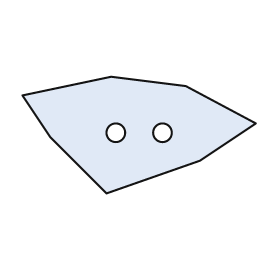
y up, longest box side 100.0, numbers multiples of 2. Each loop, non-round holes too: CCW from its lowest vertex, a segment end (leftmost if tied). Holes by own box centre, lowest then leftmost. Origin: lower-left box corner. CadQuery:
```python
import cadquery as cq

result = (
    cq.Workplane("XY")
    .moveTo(36.0, 0.0)
    .lineTo(76.0, 14.0)
    .lineTo(100.0, 30.0)
    .lineTo(70.0, 46.0)
    .lineTo(38.0, 50.0)
    .lineTo(0.0, 42.0)
    .lineTo(12.0, 24.0)
    .close()
    .moveTo(40.0, 26.0)
    .circle(4.0)
    .moveTo(60.0, 26.0)
    .circle(4.0)
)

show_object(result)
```